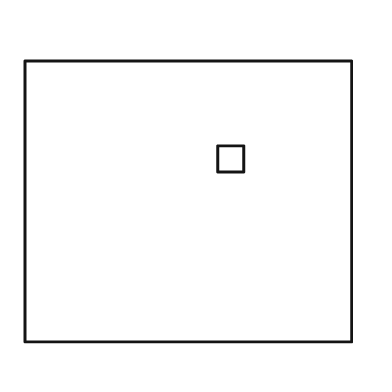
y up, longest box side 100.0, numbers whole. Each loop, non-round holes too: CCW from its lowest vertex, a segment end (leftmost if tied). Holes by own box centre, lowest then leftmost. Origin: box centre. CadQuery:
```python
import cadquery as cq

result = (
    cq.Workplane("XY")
    .moveTo(-50.0, -43.0)
    .lineTo(50.0, -43.0)
    .lineTo(50.0, 43.0)
    .lineTo(-50.0, 43.0)
    .close()
    .moveTo(9.0, 9.0)
    .lineTo(17.0, 9.0)
    .lineTo(17.0, 17.0)
    .lineTo(9.0, 17.0)
    .close()
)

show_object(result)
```